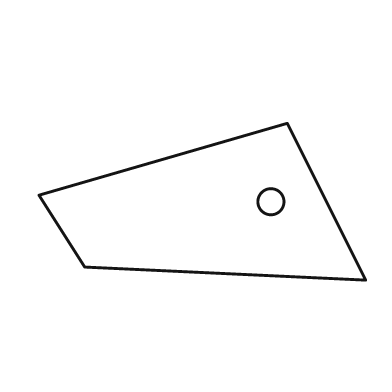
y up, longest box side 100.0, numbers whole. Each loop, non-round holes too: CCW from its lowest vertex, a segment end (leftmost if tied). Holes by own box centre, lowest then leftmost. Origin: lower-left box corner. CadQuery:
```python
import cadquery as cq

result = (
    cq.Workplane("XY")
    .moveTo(100.0, 0.0)
    .lineTo(76.0, 48.0)
    .lineTo(0.0, 26.0)
    .lineTo(14.0, 4.0)
    .close()
    .moveTo(71.0, 24.0)
    .circle(4.0)
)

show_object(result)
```